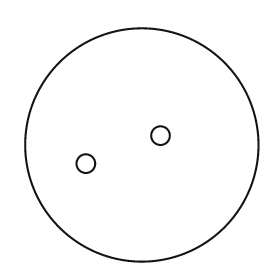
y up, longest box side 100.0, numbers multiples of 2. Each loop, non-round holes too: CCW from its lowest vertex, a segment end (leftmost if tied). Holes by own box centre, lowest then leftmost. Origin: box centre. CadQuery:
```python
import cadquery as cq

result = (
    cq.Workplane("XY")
    .moveTo(0.0, 0.0)
    .circle(50.0)
    .moveTo(-24.0, -8.0)
    .circle(4.0)
    .moveTo(8.0, 4.0)
    .circle(4.0)
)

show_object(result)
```